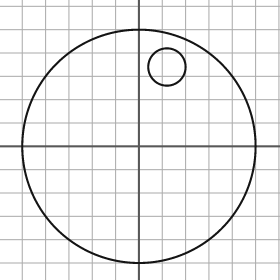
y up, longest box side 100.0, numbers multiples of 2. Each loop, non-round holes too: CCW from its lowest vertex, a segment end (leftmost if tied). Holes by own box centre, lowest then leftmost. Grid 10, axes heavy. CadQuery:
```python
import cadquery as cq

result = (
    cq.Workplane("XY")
    .moveTo(0.0, 0.0)
    .circle(50.0)
    .moveTo(12.0, 34.0)
    .circle(8.0)
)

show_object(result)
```